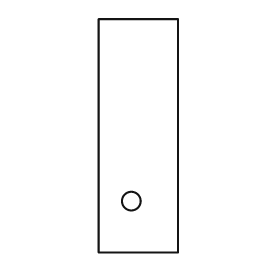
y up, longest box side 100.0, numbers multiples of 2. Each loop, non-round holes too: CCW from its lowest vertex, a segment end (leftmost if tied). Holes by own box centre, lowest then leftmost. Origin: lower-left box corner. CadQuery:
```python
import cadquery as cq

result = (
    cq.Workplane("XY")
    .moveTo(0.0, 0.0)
    .lineTo(34.0, 0.0)
    .lineTo(34.0, 100.0)
    .lineTo(0.0, 100.0)
    .close()
    .moveTo(14.0, 22.0)
    .circle(4.0)
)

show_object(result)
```